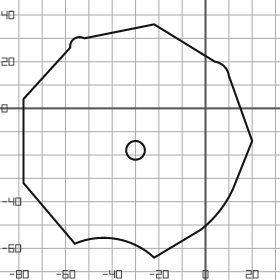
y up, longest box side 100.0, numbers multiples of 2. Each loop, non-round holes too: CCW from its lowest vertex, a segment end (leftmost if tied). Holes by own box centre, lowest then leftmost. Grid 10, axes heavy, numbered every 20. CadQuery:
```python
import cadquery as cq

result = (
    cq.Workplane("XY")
    .moveTo(-22.0, -64.0)
    .lineTo(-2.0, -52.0)
    .threePointArc((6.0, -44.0), (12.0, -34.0))
    .lineTo(20.0, -14.0)
    .lineTo(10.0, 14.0)
    .threePointArc((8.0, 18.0), (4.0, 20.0))
    .lineTo(-22.0, 36.0)
    .lineTo(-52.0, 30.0)
    .threePointArc((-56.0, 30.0), (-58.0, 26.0))
    .lineTo(-78.0, 4.0)
    .lineTo(-78.0, -32.0)
    .lineTo(-56.0, -58.0)
    .threePointArc((-38.0, -56.0), (-22.0, -64.0))
    .close()
    .moveTo(-30.0, -18.0)
    .circle(4.0)
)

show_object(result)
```